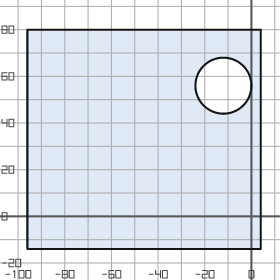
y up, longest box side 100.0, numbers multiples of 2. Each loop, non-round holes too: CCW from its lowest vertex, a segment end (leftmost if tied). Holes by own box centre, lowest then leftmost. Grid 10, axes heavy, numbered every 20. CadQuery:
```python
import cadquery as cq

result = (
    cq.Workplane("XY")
    .moveTo(-96.0, -14.0)
    .lineTo(4.0, -14.0)
    .lineTo(4.0, 80.0)
    .lineTo(-96.0, 80.0)
    .close()
    .moveTo(-12.0, 56.0)
    .circle(12.0)
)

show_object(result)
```